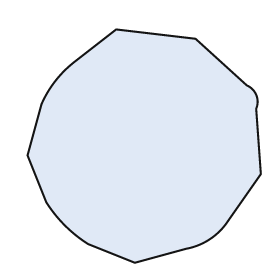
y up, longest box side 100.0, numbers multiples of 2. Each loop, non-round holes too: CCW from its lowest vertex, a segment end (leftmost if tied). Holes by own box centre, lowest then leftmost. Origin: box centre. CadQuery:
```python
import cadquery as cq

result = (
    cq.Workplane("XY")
    .moveTo(-4.0, -50.0)
    .lineTo(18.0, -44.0)
    .threePointArc((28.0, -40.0), (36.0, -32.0))
    .lineTo(50.0, -12.0)
    .lineTo(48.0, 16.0)
    .threePointArc((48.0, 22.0), (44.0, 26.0))
    .lineTo(22.0, 46.0)
    .lineTo(-12.0, 50.0)
    .lineTo(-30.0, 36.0)
    .threePointArc((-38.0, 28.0), (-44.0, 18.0))
    .lineTo(-50.0, -4.0)
    .lineTo(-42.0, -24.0)
    .threePointArc((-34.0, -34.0), (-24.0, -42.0))
    .close()
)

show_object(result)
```